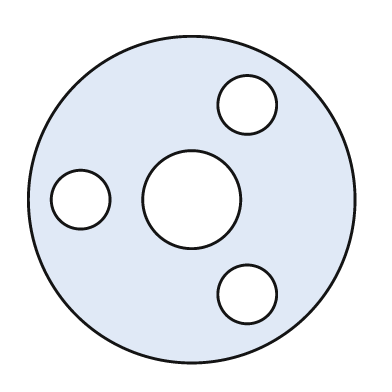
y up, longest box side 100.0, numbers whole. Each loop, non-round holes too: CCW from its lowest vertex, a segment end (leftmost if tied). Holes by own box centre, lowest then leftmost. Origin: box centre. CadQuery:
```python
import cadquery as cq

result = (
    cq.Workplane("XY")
    .moveTo(0.0, 0.0)
    .circle(50.0)
    .moveTo(17.0, -29.0)
    .circle(9.0)
    .moveTo(-34.0, 0.0)
    .circle(9.0)
    .moveTo(0.0, 0.0)
    .circle(15.0)
    .moveTo(17.0, 29.0)
    .circle(9.0)
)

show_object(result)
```